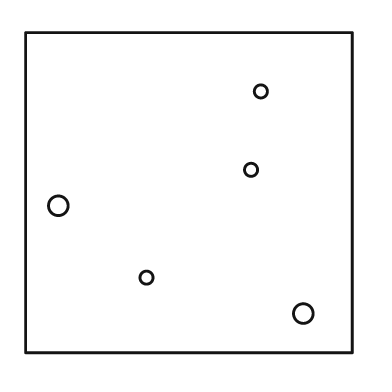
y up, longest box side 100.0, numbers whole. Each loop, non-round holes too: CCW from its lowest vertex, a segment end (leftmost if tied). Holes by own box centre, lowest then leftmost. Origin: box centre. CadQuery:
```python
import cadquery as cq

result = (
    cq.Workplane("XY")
    .moveTo(-50.0, -49.0)
    .lineTo(50.0, -49.0)
    .lineTo(50.0, 49.0)
    .lineTo(-50.0, 49.0)
    .close()
    .moveTo(35.0, -37.0)
    .circle(3.0)
    .moveTo(-13.0, -26.0)
    .circle(2.0)
    .moveTo(-40.0, -4.0)
    .circle(3.0)
    .moveTo(19.0, 7.0)
    .circle(2.0)
    .moveTo(22.0, 31.0)
    .circle(2.0)
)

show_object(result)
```